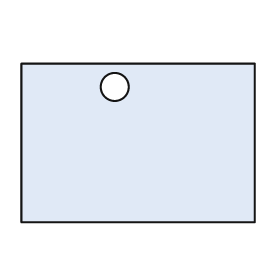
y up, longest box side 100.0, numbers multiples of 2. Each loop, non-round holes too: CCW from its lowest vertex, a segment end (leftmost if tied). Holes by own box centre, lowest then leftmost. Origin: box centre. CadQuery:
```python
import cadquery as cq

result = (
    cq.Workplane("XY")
    .moveTo(-50.0, -34.0)
    .lineTo(50.0, -34.0)
    .lineTo(50.0, 34.0)
    .lineTo(-50.0, 34.0)
    .close()
    .moveTo(-10.0, 24.0)
    .circle(6.0)
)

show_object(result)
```